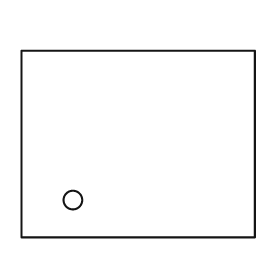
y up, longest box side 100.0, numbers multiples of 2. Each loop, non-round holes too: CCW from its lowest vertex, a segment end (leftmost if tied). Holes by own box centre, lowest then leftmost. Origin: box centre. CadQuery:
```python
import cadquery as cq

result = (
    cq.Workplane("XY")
    .moveTo(-50.0, -40.0)
    .lineTo(50.0, -40.0)
    .lineTo(50.0, 40.0)
    .lineTo(-50.0, 40.0)
    .close()
    .moveTo(-28.0, -24.0)
    .circle(4.0)
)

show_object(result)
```